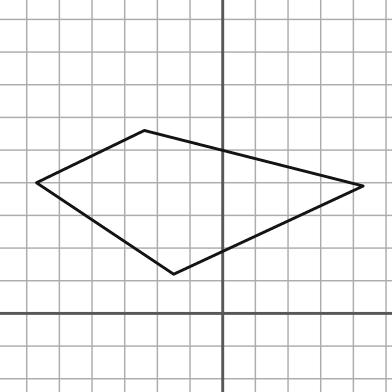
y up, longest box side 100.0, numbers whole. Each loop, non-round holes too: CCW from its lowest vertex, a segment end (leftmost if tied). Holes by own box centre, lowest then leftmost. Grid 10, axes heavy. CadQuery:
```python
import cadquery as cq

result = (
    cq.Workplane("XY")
    .moveTo(-15.0, 12.0)
    .lineTo(43.0, 39.0)
    .lineTo(-24.0, 56.0)
    .lineTo(-57.0, 40.0)
    .close()
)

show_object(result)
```